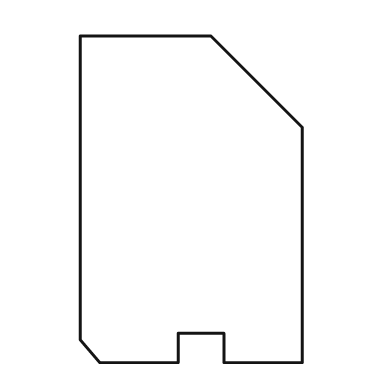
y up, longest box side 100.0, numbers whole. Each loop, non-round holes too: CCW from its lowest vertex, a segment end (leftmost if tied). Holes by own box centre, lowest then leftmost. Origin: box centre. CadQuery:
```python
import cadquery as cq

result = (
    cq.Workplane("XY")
    .moveTo(-28.0, -50.0)
    .lineTo(-4.0, -50.0)
    .lineTo(-4.0, -41.0)
    .lineTo(10.0, -41.0)
    .lineTo(10.0, -50.0)
    .lineTo(34.0, -50.0)
    .lineTo(34.0, 22.0)
    .lineTo(6.0, 50.0)
    .lineTo(-34.0, 50.0)
    .lineTo(-34.0, -43.0)
    .close()
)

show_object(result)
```